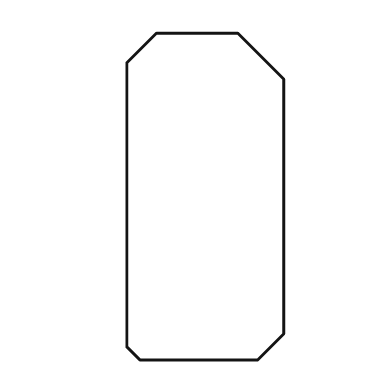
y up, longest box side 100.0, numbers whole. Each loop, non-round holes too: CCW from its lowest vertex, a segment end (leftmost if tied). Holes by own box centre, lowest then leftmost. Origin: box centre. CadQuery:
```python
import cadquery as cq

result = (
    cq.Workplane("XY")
    .moveTo(-20.0, -50.0)
    .lineTo(16.0, -50.0)
    .lineTo(24.0, -42.0)
    .lineTo(24.0, 36.0)
    .lineTo(10.0, 50.0)
    .lineTo(-15.0, 50.0)
    .lineTo(-24.0, 41.0)
    .lineTo(-24.0, -46.0)
    .close()
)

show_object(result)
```